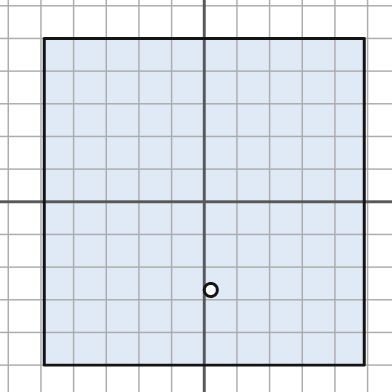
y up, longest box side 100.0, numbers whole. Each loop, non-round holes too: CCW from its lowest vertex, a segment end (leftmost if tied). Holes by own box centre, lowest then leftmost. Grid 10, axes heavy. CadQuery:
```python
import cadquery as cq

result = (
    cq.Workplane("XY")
    .moveTo(-49.0, -50.0)
    .lineTo(49.0, -50.0)
    .lineTo(49.0, 50.0)
    .lineTo(-49.0, 50.0)
    .close()
    .moveTo(2.0, -27.0)
    .circle(2.0)
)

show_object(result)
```